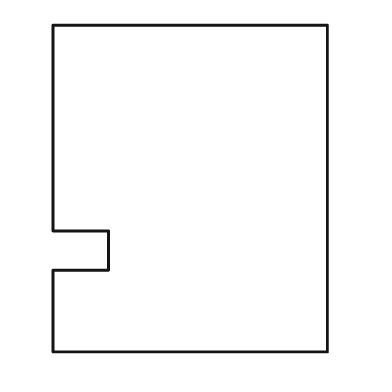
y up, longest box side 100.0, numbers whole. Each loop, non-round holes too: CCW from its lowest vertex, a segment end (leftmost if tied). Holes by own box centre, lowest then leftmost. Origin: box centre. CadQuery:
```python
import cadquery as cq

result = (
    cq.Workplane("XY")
    .moveTo(-42.0, -50.0)
    .lineTo(42.0, -50.0)
    .lineTo(42.0, 50.0)
    .lineTo(-42.0, 50.0)
    .lineTo(-42.0, -13.0)
    .lineTo(-25.0, -13.0)
    .lineTo(-25.0, -25.0)
    .lineTo(-42.0, -25.0)
    .close()
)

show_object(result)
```